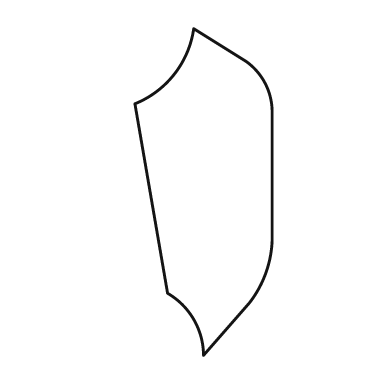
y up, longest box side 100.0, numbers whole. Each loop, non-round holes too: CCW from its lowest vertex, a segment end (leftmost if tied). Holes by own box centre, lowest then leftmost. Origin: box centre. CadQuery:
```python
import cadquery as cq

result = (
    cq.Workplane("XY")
    .moveTo(0.0, -50.0)
    .lineTo(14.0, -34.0)
    .threePointArc((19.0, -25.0), (21.0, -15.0))
    .lineTo(21.0, 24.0)
    .threePointArc((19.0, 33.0), (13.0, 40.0))
    .lineTo(-3.0, 50.0)
    .threePointArc((-9.0, 36.0), (-21.0, 27.0))
    .lineTo(-11.0, -31.0)
    .threePointArc((-3.0, -39.0), (0.0, -50.0))
    .close()
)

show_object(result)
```